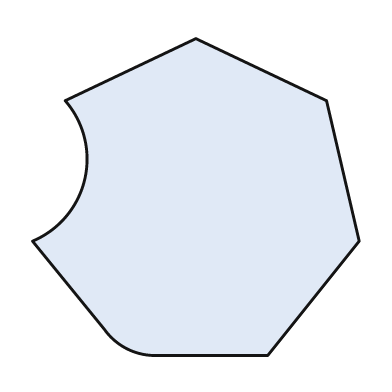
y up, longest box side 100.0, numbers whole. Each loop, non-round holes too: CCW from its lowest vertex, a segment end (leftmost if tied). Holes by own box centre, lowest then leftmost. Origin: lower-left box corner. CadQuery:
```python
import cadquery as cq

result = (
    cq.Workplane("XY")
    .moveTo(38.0, 0.0)
    .lineTo(72.0, 0.0)
    .lineTo(100.0, 35.0)
    .lineTo(90.0, 78.0)
    .lineTo(50.0, 97.0)
    .lineTo(10.0, 78.0)
    .threePointArc((16.0, 54.0), (0.0, 35.0))
    .lineTo(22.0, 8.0)
    .threePointArc((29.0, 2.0), (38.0, 0.0))
    .close()
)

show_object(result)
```